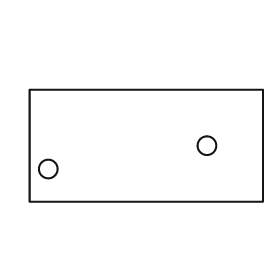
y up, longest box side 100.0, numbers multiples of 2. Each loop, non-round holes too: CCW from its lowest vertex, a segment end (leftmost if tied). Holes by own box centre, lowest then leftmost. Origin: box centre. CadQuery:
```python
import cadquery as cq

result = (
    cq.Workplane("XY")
    .moveTo(-50.0, -24.0)
    .lineTo(50.0, -24.0)
    .lineTo(50.0, 24.0)
    .lineTo(-50.0, 24.0)
    .close()
    .moveTo(-42.0, -10.0)
    .circle(4.0)
    .moveTo(26.0, 0.0)
    .circle(4.0)
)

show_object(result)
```